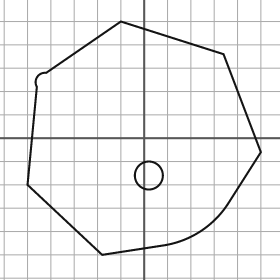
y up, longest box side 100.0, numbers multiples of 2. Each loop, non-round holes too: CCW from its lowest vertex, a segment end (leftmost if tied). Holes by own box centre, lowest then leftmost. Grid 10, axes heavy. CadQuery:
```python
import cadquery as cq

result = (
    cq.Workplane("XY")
    .moveTo(-18.0, -50.0)
    .lineTo(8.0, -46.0)
    .threePointArc((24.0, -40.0), (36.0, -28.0))
    .lineTo(50.0, -6.0)
    .lineTo(34.0, 36.0)
    .lineTo(-10.0, 50.0)
    .lineTo(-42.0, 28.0)
    .threePointArc((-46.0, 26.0), (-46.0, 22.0))
    .lineTo(-50.0, -20.0)
    .close()
    .moveTo(2.0, -16.0)
    .circle(6.0)
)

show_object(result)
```